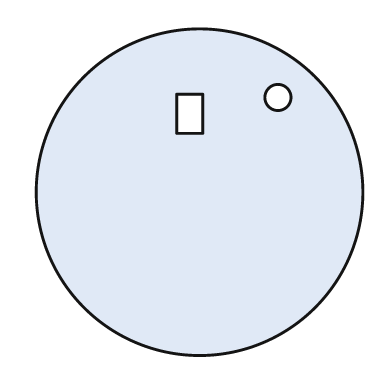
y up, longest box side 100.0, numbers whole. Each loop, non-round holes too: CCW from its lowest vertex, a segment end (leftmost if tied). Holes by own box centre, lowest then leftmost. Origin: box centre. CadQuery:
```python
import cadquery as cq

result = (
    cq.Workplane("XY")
    .moveTo(0.0, 0.0)
    .circle(50.0)
    .moveTo(-7.0, 18.0)
    .lineTo(1.0, 18.0)
    .lineTo(1.0, 30.0)
    .lineTo(-7.0, 30.0)
    .close()
    .moveTo(24.0, 29.0)
    .circle(4.0)
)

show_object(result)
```